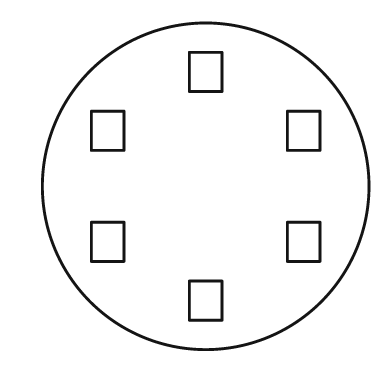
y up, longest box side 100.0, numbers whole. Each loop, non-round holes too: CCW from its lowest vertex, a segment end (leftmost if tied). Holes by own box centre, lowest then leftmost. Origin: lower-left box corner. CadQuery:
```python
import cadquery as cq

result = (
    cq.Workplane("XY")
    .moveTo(50.0, 50.0)
    .circle(50.0)
    .moveTo(45.0, 9.0)
    .lineTo(55.0, 9.0)
    .lineTo(55.0, 21.0)
    .lineTo(45.0, 21.0)
    .close()
    .moveTo(15.0, 27.0)
    .lineTo(25.0, 27.0)
    .lineTo(25.0, 39.0)
    .lineTo(15.0, 39.0)
    .close()
    .moveTo(75.0, 27.0)
    .lineTo(85.0, 27.0)
    .lineTo(85.0, 39.0)
    .lineTo(75.0, 39.0)
    .close()
    .moveTo(15.0, 61.0)
    .lineTo(25.0, 61.0)
    .lineTo(25.0, 73.0)
    .lineTo(15.0, 73.0)
    .close()
    .moveTo(75.0, 61.0)
    .lineTo(85.0, 61.0)
    .lineTo(85.0, 73.0)
    .lineTo(75.0, 73.0)
    .close()
    .moveTo(45.0, 79.0)
    .lineTo(55.0, 79.0)
    .lineTo(55.0, 91.0)
    .lineTo(45.0, 91.0)
    .close()
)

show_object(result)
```